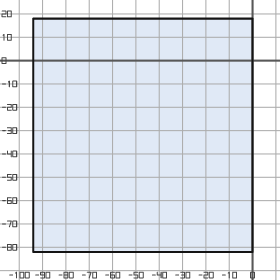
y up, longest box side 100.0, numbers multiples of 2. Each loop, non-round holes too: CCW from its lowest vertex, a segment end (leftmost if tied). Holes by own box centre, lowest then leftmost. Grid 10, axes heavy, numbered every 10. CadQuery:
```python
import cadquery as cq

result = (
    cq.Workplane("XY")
    .moveTo(-94.0, -82.0)
    .lineTo(0.0, -82.0)
    .lineTo(0.0, 18.0)
    .lineTo(-94.0, 18.0)
    .close()
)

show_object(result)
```